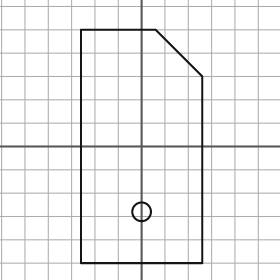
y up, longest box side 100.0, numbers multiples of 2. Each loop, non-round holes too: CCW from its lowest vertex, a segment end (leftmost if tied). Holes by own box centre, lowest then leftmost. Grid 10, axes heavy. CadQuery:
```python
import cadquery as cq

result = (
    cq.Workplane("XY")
    .moveTo(-26.0, -50.0)
    .lineTo(26.0, -50.0)
    .lineTo(26.0, 30.0)
    .lineTo(6.0, 50.0)
    .lineTo(-26.0, 50.0)
    .close()
    .moveTo(0.0, -28.0)
    .circle(4.0)
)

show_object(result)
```